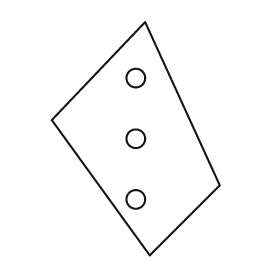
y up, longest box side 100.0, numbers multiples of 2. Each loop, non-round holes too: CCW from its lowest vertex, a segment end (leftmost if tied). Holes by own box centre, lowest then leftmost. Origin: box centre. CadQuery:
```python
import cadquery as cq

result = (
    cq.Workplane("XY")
    .moveTo(6.0, -50.0)
    .lineTo(36.0, -20.0)
    .lineTo(4.0, 50.0)
    .lineTo(-36.0, 8.0)
    .close()
    .moveTo(0.0, -26.0)
    .circle(4.0)
    .moveTo(0.0, 0.0)
    .circle(4.0)
    .moveTo(0.0, 26.0)
    .circle(4.0)
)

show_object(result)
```